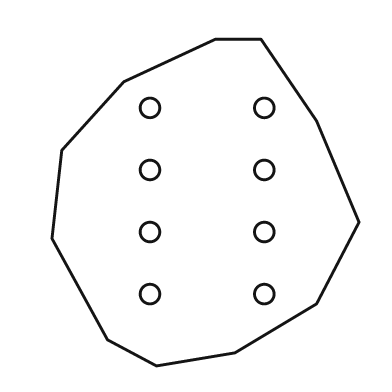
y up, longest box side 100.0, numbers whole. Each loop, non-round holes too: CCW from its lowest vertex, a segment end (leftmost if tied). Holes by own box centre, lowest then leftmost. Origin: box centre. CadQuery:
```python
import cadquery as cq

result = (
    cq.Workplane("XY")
    .moveTo(-15.0, -50.0)
    .lineTo(9.0, -46.0)
    .lineTo(34.0, -31.0)
    .lineTo(47.0, -6.0)
    .lineTo(34.0, 25.0)
    .lineTo(17.0, 50.0)
    .lineTo(3.0, 50.0)
    .lineTo(-25.0, 37.0)
    .lineTo(-44.0, 16.0)
    .lineTo(-47.0, -11.0)
    .lineTo(-30.0, -42.0)
    .close()
    .moveTo(-17.0, -28.0)
    .circle(3.0)
    .moveTo(18.0, -28.0)
    .circle(3.0)
    .moveTo(-17.0, -9.0)
    .circle(3.0)
    .moveTo(18.0, -9.0)
    .circle(3.0)
    .moveTo(-17.0, 10.0)
    .circle(3.0)
    .moveTo(18.0, 10.0)
    .circle(3.0)
    .moveTo(-17.0, 29.0)
    .circle(3.0)
    .moveTo(18.0, 29.0)
    .circle(3.0)
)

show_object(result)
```